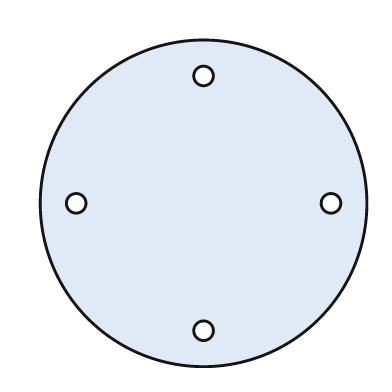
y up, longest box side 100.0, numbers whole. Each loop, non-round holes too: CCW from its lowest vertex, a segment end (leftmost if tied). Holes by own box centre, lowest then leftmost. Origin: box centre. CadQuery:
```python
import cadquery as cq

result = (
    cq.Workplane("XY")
    .moveTo(0.0, 0.0)
    .circle(50.0)
    .moveTo(0.0, -39.0)
    .circle(3.0)
    .moveTo(-39.0, 0.0)
    .circle(3.0)
    .moveTo(39.0, 0.0)
    .circle(3.0)
    .moveTo(0.0, 39.0)
    .circle(3.0)
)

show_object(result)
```